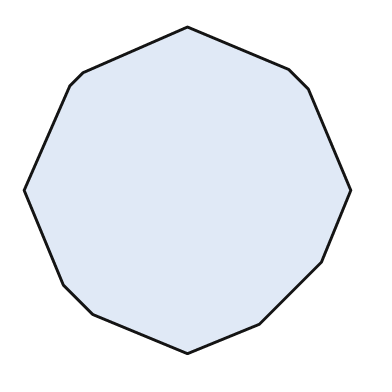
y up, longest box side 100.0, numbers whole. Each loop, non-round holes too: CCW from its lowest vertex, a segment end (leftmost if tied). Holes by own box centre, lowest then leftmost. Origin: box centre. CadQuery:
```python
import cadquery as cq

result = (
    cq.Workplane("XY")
    .moveTo(0.0, -50.0)
    .lineTo(22.0, -41.0)
    .lineTo(41.0, -22.0)
    .lineTo(50.0, 0.0)
    .lineTo(37.0, 31.0)
    .lineTo(31.0, 37.0)
    .lineTo(0.0, 50.0)
    .lineTo(-32.0, 36.0)
    .lineTo(-36.0, 32.0)
    .lineTo(-50.0, 0.0)
    .lineTo(-38.0, -29.0)
    .lineTo(-29.0, -38.0)
    .close()
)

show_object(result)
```